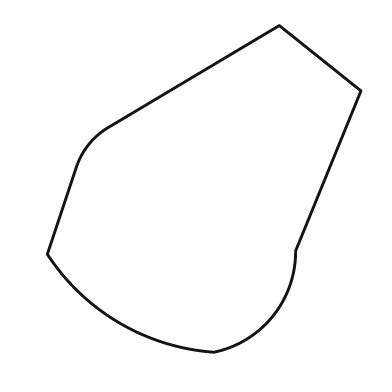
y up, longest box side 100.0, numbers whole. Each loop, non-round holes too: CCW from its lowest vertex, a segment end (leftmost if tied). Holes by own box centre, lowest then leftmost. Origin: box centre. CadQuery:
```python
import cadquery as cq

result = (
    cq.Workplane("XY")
    .moveTo(3.0, -50.0)
    .threePointArc((21.0, -39.0), (28.0, -19.0))
    .lineTo(48.0, 30.0)
    .lineTo(23.0, 50.0)
    .lineTo(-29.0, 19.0)
    .threePointArc((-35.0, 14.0), (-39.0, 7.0))
    .lineTo(-48.0, -20.0)
    .threePointArc((-26.0, -41.0), (3.0, -50.0))
    .close()
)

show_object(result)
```